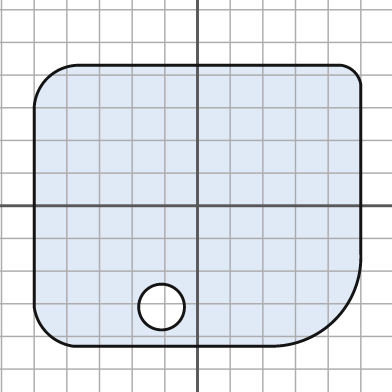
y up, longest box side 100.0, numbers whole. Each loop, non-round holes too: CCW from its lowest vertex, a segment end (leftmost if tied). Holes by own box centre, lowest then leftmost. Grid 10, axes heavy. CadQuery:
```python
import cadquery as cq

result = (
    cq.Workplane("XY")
    .moveTo(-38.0, -43.0)
    .lineTo(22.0, -43.0)
    .threePointArc((42.0, -35.0), (50.0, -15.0))
    .lineTo(50.0, 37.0)
    .threePointArc((48.0, 41.0), (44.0, 43.0))
    .lineTo(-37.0, 43.0)
    .threePointArc((-46.0, 39.0), (-50.0, 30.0))
    .lineTo(-50.0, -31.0)
    .threePointArc((-46.0, -39.0), (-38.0, -43.0))
    .close()
    .moveTo(-11.0, -31.0)
    .circle(7.0)
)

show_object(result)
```